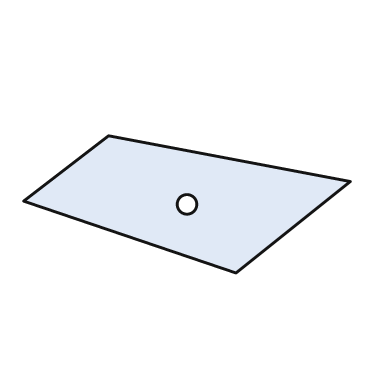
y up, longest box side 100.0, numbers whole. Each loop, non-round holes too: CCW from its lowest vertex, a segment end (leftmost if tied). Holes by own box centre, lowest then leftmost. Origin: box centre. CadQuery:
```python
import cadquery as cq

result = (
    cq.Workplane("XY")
    .moveTo(15.0, -21.0)
    .lineTo(50.0, 7.0)
    .lineTo(-24.0, 21.0)
    .lineTo(-50.0, 1.0)
    .close()
    .moveTo(0.0, 0.0)
    .circle(3.0)
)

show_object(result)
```